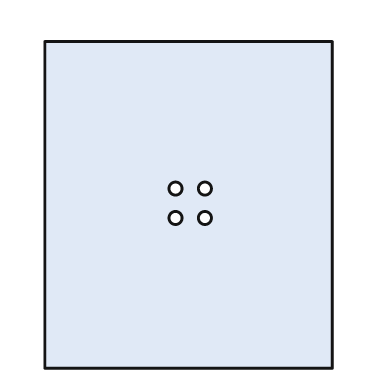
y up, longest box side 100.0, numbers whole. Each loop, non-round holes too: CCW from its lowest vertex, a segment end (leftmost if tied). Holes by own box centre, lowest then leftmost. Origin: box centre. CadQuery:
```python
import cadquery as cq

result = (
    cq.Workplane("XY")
    .moveTo(-44.0, -50.0)
    .lineTo(44.0, -50.0)
    .lineTo(44.0, 50.0)
    .lineTo(-44.0, 50.0)
    .close()
    .moveTo(-4.0, -4.0)
    .circle(2.0)
    .moveTo(5.0, -4.0)
    .circle(2.0)
    .moveTo(-4.0, 5.0)
    .circle(2.0)
    .moveTo(5.0, 5.0)
    .circle(2.0)
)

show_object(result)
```